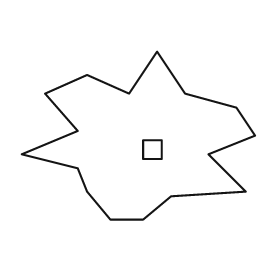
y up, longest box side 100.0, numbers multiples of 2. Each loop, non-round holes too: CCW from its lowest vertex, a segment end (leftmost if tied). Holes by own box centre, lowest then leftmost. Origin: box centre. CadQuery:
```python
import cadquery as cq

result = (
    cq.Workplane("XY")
    .moveTo(-12.0, -36.0)
    .lineTo(2.0, -36.0)
    .lineTo(14.0, -26.0)
    .lineTo(46.0, -24.0)
    .lineTo(30.0, -8.0)
    .lineTo(50.0, 0.0)
    .lineTo(42.0, 12.0)
    .lineTo(20.0, 18.0)
    .lineTo(8.0, 36.0)
    .lineTo(-4.0, 18.0)
    .lineTo(-22.0, 26.0)
    .lineTo(-40.0, 18.0)
    .lineTo(-26.0, 2.0)
    .lineTo(-50.0, -8.0)
    .lineTo(-26.0, -14.0)
    .lineTo(-22.0, -24.0)
    .close()
    .moveTo(2.0, -10.0)
    .lineTo(10.0, -10.0)
    .lineTo(10.0, -2.0)
    .lineTo(2.0, -2.0)
    .close()
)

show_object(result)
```